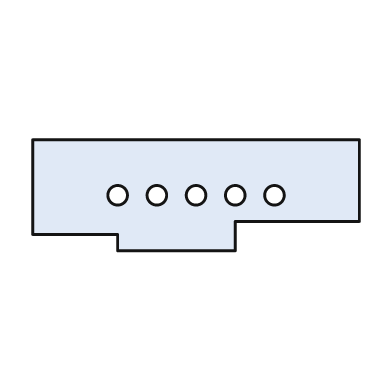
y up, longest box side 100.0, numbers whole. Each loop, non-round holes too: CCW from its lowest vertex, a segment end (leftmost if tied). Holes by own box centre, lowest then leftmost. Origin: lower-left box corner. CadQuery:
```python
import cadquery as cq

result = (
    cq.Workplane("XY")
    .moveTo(26.0, 0.0)
    .lineTo(62.0, 0.0)
    .lineTo(62.0, 9.0)
    .lineTo(100.0, 9.0)
    .lineTo(100.0, 34.0)
    .lineTo(0.0, 34.0)
    .lineTo(0.0, 5.0)
    .lineTo(26.0, 5.0)
    .close()
    .moveTo(26.0, 17.0)
    .circle(3.0)
    .moveTo(38.0, 17.0)
    .circle(3.0)
    .moveTo(50.0, 17.0)
    .circle(3.0)
    .moveTo(62.0, 17.0)
    .circle(3.0)
    .moveTo(74.0, 17.0)
    .circle(3.0)
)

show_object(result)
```